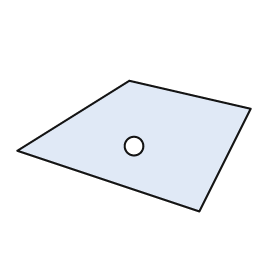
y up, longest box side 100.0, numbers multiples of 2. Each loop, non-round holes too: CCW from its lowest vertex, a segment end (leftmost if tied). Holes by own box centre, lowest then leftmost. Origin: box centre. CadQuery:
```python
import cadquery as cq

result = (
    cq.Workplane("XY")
    .moveTo(28.0, -28.0)
    .lineTo(50.0, 16.0)
    .lineTo(-2.0, 28.0)
    .lineTo(-50.0, -2.0)
    .close()
    .moveTo(0.0, 0.0)
    .circle(4.0)
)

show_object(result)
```